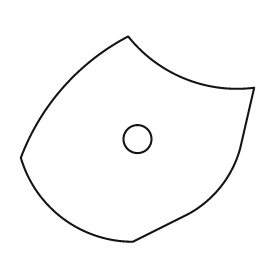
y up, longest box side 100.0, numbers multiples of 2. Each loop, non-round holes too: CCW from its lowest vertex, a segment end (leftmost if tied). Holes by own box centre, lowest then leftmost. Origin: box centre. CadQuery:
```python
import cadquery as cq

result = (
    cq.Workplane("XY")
    .moveTo(-2.0, -44.0)
    .lineTo(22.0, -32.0)
    .threePointArc((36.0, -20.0), (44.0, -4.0))
    .lineTo(50.0, 22.0)
    .threePointArc((20.0, 26.0), (-4.0, 44.0))
    .threePointArc((-32.0, 22.0), (-50.0, -8.0))
    .threePointArc((-32.0, -34.0), (-2.0, -44.0))
    .close()
    .moveTo(0.0, 0.0)
    .circle(6.0)
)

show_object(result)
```